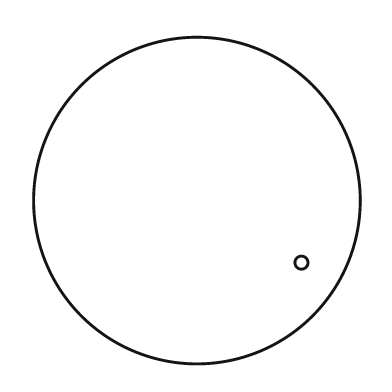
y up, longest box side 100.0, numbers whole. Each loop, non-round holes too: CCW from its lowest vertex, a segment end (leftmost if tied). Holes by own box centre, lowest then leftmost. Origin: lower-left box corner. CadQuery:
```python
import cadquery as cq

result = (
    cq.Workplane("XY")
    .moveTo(50.0, 50.0)
    .circle(50.0)
    .moveTo(82.0, 31.0)
    .circle(2.0)
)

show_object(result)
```